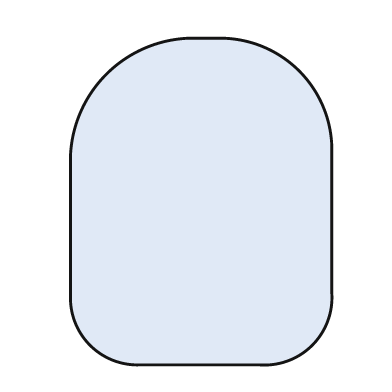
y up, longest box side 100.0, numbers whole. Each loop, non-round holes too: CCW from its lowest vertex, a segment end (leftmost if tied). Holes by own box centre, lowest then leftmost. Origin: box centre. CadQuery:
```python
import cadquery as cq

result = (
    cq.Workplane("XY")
    .moveTo(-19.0, -50.0)
    .lineTo(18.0, -50.0)
    .threePointArc((34.0, -44.0), (40.0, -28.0))
    .lineTo(40.0, 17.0)
    .threePointArc((30.0, 40.0), (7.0, 50.0))
    .lineTo(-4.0, 50.0)
    .threePointArc((-29.0, 39.0), (-40.0, 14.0))
    .lineTo(-40.0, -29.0)
    .threePointArc((-34.0, -44.0), (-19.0, -50.0))
    .close()
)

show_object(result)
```